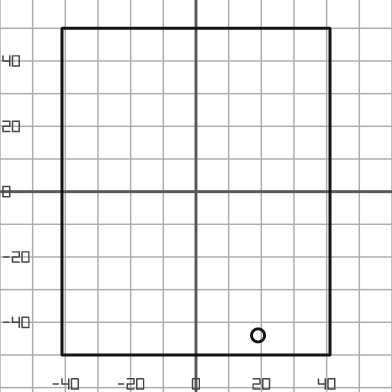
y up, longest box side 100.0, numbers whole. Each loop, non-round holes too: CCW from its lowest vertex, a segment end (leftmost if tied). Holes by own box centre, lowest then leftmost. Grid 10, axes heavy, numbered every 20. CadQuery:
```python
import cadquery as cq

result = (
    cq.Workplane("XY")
    .moveTo(-41.0, -50.0)
    .lineTo(41.0, -50.0)
    .lineTo(41.0, 50.0)
    .lineTo(-41.0, 50.0)
    .close()
    .moveTo(19.0, -44.0)
    .circle(2.0)
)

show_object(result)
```